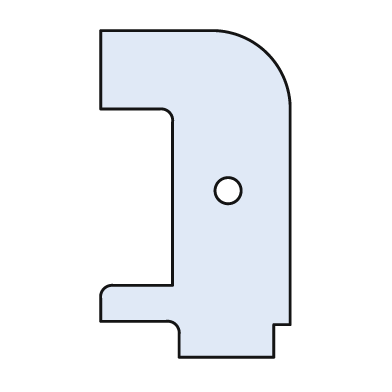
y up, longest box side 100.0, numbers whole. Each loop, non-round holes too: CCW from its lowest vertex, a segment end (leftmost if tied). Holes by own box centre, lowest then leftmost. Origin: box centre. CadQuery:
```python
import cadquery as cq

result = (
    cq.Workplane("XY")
    .moveTo(-5.0, -50.0)
    .lineTo(24.0, -50.0)
    .lineTo(24.0, -40.0)
    .lineTo(29.0, -40.0)
    .lineTo(29.0, 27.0)
    .threePointArc((22.0, 43.0), (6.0, 50.0))
    .lineTo(-29.0, 50.0)
    .lineTo(-29.0, 26.0)
    .lineTo(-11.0, 26.0)
    .threePointArc((-8.0, 25.0), (-7.0, 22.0))
    .lineTo(-7.0, -28.0)
    .lineTo(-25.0, -28.0)
    .threePointArc((-28.0, -29.0), (-29.0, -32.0))
    .lineTo(-29.0, -39.0)
    .lineTo(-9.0, -39.0)
    .threePointArc((-6.0, -40.0), (-5.0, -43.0))
    .close()
    .moveTo(10.0, 1.0)
    .circle(4.0)
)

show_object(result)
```